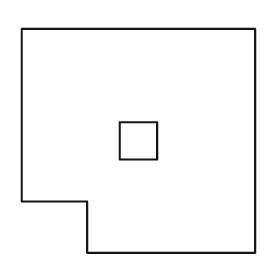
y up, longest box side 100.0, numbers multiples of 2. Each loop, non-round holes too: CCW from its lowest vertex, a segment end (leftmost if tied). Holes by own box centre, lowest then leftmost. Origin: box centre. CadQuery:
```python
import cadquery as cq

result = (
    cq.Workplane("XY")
    .moveTo(-22.0, -48.0)
    .lineTo(50.0, -48.0)
    .lineTo(50.0, 48.0)
    .lineTo(-50.0, 48.0)
    .lineTo(-50.0, -26.0)
    .lineTo(-22.0, -26.0)
    .close()
    .moveTo(-8.0, -8.0)
    .lineTo(8.0, -8.0)
    .lineTo(8.0, 8.0)
    .lineTo(-8.0, 8.0)
    .close()
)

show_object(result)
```